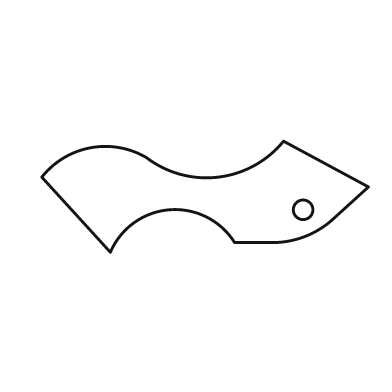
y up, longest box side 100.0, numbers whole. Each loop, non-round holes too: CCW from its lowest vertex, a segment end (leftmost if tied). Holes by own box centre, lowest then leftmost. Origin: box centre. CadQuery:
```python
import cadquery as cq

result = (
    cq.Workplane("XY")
    .moveTo(-29.0, -17.0)
    .threePointArc((-11.0, -4.0), (9.0, -14.0))
    .lineTo(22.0, -14.0)
    .threePointArc((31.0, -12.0), (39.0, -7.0))
    .lineTo(50.0, 3.0)
    .lineTo(24.0, 17.0)
    .threePointArc((4.0, 6.0), (-18.0, 12.0))
    .threePointArc((-35.0, 15.0), (-50.0, 6.0))
    .close()
    .moveTo(30.0, -4.0)
    .circle(3.0)
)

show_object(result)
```